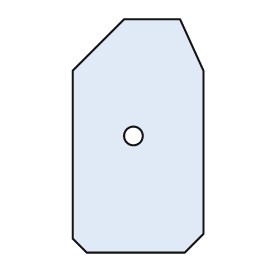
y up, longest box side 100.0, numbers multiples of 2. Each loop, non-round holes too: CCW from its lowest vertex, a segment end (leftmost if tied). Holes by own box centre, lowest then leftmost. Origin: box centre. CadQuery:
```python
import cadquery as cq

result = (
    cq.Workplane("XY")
    .moveTo(-22.0, -50.0)
    .lineTo(20.0, -50.0)
    .lineTo(28.0, -42.0)
    .lineTo(28.0, 28.0)
    .lineTo(18.0, 50.0)
    .lineTo(-6.0, 50.0)
    .lineTo(-28.0, 28.0)
    .lineTo(-28.0, -44.0)
    .close()
    .moveTo(-2.0, 0.0)
    .circle(4.0)
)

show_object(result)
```